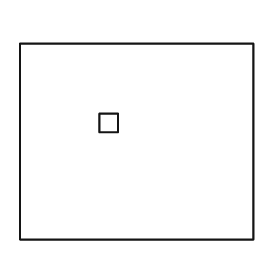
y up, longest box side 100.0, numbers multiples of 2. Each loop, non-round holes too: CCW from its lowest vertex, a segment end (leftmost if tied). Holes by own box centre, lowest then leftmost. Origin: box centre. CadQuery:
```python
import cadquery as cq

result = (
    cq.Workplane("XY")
    .moveTo(-50.0, -42.0)
    .lineTo(50.0, -42.0)
    .lineTo(50.0, 42.0)
    .lineTo(-50.0, 42.0)
    .close()
    .moveTo(-16.0, 4.0)
    .lineTo(-8.0, 4.0)
    .lineTo(-8.0, 12.0)
    .lineTo(-16.0, 12.0)
    .close()
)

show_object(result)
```